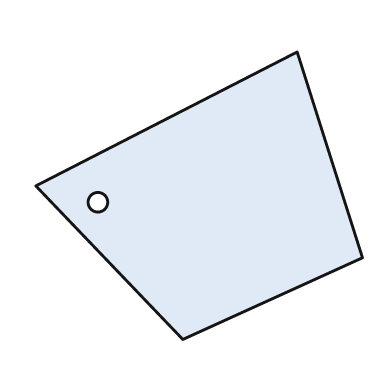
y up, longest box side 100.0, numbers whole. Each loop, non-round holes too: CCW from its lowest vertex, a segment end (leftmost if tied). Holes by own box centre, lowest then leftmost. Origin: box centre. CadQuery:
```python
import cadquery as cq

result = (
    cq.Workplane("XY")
    .moveTo(-5.0, -44.0)
    .lineTo(50.0, -19.0)
    .lineTo(30.0, 44.0)
    .lineTo(-50.0, 3.0)
    .close()
    .moveTo(-31.0, -2.0)
    .circle(3.0)
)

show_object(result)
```